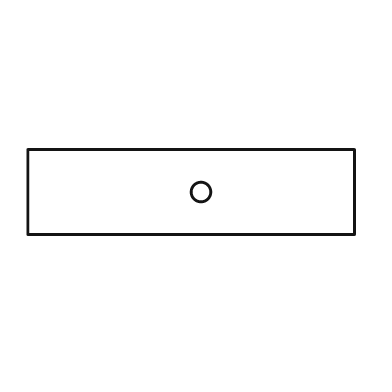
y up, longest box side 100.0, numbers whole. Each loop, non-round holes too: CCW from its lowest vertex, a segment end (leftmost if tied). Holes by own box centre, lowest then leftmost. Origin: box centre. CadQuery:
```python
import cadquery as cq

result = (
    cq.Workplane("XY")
    .moveTo(-50.0, -13.0)
    .lineTo(50.0, -13.0)
    .lineTo(50.0, 13.0)
    .lineTo(-50.0, 13.0)
    .close()
    .moveTo(3.0, 0.0)
    .circle(3.0)
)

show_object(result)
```